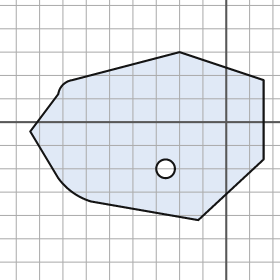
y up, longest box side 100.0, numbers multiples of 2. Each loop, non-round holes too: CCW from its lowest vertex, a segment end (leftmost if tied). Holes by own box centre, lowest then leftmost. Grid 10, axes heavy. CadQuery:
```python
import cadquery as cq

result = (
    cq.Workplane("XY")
    .moveTo(-12.0, -42.0)
    .lineTo(16.0, -16.0)
    .lineTo(16.0, 18.0)
    .lineTo(-20.0, 30.0)
    .lineTo(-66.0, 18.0)
    .threePointArc((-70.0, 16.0), (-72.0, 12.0))
    .lineTo(-84.0, -4.0)
    .lineTo(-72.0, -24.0)
    .threePointArc((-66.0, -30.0), (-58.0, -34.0))
    .close()
    .moveTo(-26.0, -20.0)
    .circle(4.0)
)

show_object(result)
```